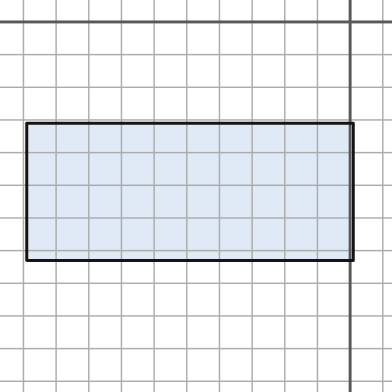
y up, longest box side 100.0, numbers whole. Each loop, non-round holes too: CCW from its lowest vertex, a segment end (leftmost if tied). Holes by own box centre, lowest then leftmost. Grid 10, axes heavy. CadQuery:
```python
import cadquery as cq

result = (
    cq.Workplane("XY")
    .moveTo(-99.0, -73.0)
    .lineTo(1.0, -73.0)
    .lineTo(1.0, -31.0)
    .lineTo(-99.0, -31.0)
    .close()
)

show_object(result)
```